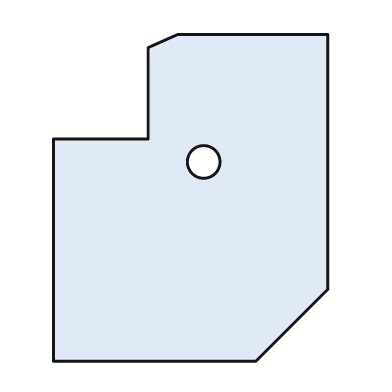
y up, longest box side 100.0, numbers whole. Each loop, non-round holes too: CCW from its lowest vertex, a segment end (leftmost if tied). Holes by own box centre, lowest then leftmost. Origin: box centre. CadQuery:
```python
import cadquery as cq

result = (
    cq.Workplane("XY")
    .moveTo(-42.0, -50.0)
    .lineTo(20.0, -50.0)
    .lineTo(42.0, -28.0)
    .lineTo(42.0, 50.0)
    .lineTo(-4.0, 50.0)
    .lineTo(-13.0, 46.0)
    .lineTo(-13.0, 18.0)
    .lineTo(-42.0, 18.0)
    .close()
    .moveTo(4.0, 11.0)
    .circle(5.0)
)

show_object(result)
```